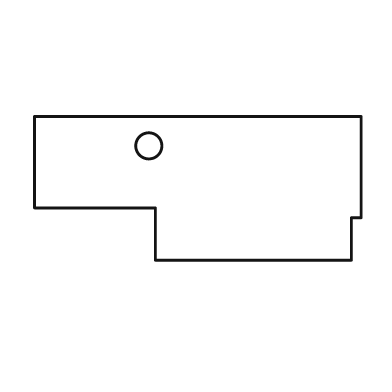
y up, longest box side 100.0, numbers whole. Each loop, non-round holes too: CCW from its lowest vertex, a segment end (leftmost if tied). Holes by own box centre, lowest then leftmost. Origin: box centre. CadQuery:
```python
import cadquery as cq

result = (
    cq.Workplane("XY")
    .moveTo(-13.0, -22.0)
    .lineTo(47.0, -22.0)
    .lineTo(47.0, -9.0)
    .lineTo(50.0, -9.0)
    .lineTo(50.0, 22.0)
    .lineTo(-50.0, 22.0)
    .lineTo(-50.0, -6.0)
    .lineTo(-13.0, -6.0)
    .close()
    .moveTo(-15.0, 13.0)
    .circle(4.0)
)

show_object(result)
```